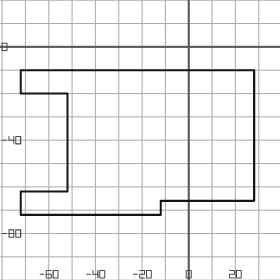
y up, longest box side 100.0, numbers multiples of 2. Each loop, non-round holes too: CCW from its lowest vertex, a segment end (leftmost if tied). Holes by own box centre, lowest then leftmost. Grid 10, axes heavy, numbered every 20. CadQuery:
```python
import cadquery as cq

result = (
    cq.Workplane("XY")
    .moveTo(-72.0, -72.0)
    .lineTo(-12.0, -72.0)
    .lineTo(-12.0, -66.0)
    .lineTo(28.0, -66.0)
    .lineTo(28.0, -10.0)
    .lineTo(-72.0, -10.0)
    .lineTo(-72.0, -20.0)
    .lineTo(-52.0, -20.0)
    .lineTo(-52.0, -62.0)
    .lineTo(-72.0, -62.0)
    .close()
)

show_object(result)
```